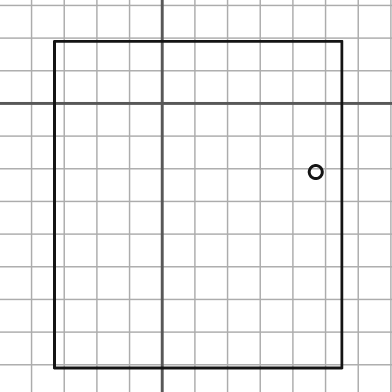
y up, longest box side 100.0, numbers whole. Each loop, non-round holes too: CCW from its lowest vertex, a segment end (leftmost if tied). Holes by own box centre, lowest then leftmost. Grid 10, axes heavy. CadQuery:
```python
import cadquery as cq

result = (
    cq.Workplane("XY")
    .moveTo(-33.0, -81.0)
    .lineTo(55.0, -81.0)
    .lineTo(55.0, 19.0)
    .lineTo(-33.0, 19.0)
    .close()
    .moveTo(47.0, -21.0)
    .circle(2.0)
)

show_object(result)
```